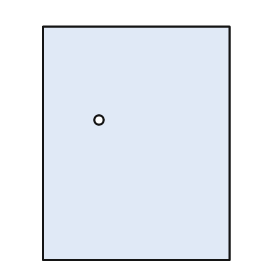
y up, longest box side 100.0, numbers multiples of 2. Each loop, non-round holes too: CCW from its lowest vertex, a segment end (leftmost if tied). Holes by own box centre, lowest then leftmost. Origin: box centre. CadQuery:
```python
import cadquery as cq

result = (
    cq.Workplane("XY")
    .moveTo(-40.0, -50.0)
    .lineTo(40.0, -50.0)
    .lineTo(40.0, 50.0)
    .lineTo(-40.0, 50.0)
    .close()
    .moveTo(-16.0, 10.0)
    .circle(2.0)
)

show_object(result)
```